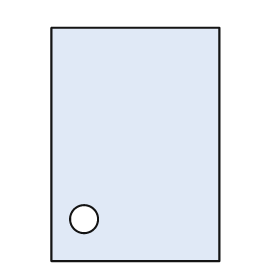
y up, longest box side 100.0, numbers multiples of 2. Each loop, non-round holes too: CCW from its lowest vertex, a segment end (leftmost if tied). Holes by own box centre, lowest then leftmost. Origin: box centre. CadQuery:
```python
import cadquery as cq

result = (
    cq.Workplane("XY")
    .moveTo(-36.0, -50.0)
    .lineTo(36.0, -50.0)
    .lineTo(36.0, 50.0)
    .lineTo(-36.0, 50.0)
    .close()
    .moveTo(-22.0, -32.0)
    .circle(6.0)
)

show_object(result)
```